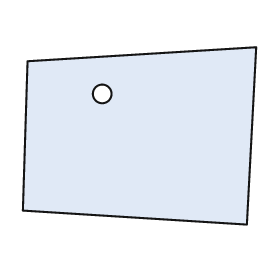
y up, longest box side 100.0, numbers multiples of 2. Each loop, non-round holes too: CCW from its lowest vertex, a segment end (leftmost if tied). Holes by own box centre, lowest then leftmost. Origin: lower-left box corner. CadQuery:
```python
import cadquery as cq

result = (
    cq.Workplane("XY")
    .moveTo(96.0, 0.0)
    .lineTo(100.0, 76.0)
    .lineTo(2.0, 70.0)
    .lineTo(0.0, 6.0)
    .close()
    .moveTo(34.0, 56.0)
    .circle(4.0)
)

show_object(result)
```